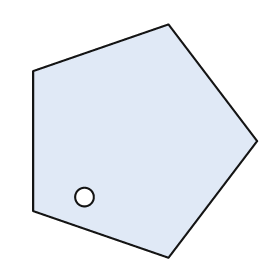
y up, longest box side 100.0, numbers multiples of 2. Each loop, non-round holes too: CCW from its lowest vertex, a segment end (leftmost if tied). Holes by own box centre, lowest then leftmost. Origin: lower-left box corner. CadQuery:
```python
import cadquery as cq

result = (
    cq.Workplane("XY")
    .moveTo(58.0, 0.0)
    .lineTo(96.0, 50.0)
    .lineTo(58.0, 100.0)
    .lineTo(0.0, 80.0)
    .lineTo(0.0, 20.0)
    .close()
    .moveTo(22.0, 26.0)
    .circle(4.0)
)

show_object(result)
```